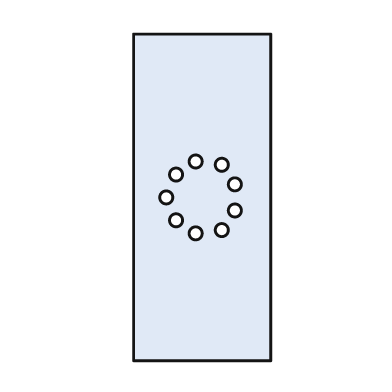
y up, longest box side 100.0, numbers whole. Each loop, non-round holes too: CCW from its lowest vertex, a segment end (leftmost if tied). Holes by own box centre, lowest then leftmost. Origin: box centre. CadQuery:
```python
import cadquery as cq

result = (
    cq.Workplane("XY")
    .moveTo(-21.0, -50.0)
    .lineTo(21.0, -50.0)
    .lineTo(21.0, 50.0)
    .lineTo(-21.0, 50.0)
    .close()
    .moveTo(-2.0, -11.0)
    .circle(2.0)
    .moveTo(6.0, -10.0)
    .circle(2.0)
    .moveTo(-8.0, -7.0)
    .circle(2.0)
    .moveTo(10.0, -4.0)
    .circle(2.0)
    .moveTo(-11.0, 0.0)
    .circle(2.0)
    .moveTo(10.0, 4.0)
    .circle(2.0)
    .moveTo(-8.0, 7.0)
    .circle(2.0)
    .moveTo(6.0, 10.0)
    .circle(2.0)
    .moveTo(-2.0, 11.0)
    .circle(2.0)
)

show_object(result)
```